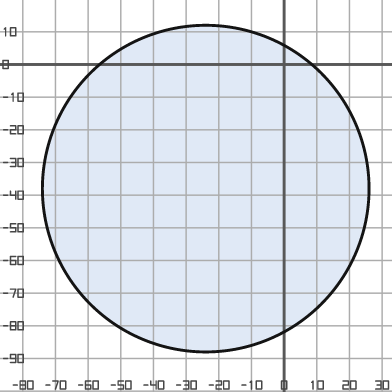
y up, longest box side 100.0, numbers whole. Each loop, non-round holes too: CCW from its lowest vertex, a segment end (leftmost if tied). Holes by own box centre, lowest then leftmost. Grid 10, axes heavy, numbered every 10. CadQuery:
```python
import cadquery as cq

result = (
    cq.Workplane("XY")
    .moveTo(-24.0, -38.0)
    .circle(50.0)
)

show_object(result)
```